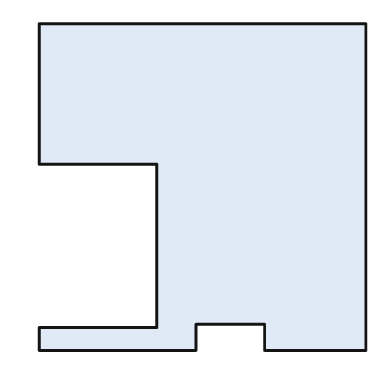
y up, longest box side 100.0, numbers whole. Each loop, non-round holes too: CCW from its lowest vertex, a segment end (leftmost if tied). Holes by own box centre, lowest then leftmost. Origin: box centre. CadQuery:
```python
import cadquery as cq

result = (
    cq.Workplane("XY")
    .moveTo(-50.0, -50.0)
    .lineTo(-2.0, -50.0)
    .lineTo(-2.0, -42.0)
    .lineTo(19.0, -42.0)
    .lineTo(19.0, -50.0)
    .lineTo(50.0, -50.0)
    .lineTo(50.0, 50.0)
    .lineTo(-50.0, 50.0)
    .lineTo(-50.0, 7.0)
    .lineTo(-14.0, 7.0)
    .lineTo(-14.0, -43.0)
    .lineTo(-50.0, -43.0)
    .close()
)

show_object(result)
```